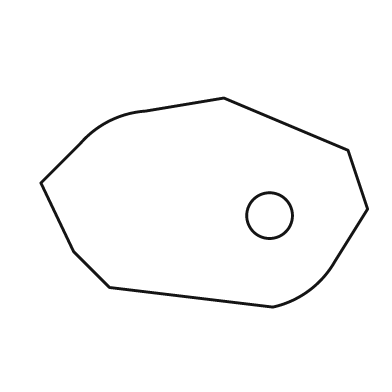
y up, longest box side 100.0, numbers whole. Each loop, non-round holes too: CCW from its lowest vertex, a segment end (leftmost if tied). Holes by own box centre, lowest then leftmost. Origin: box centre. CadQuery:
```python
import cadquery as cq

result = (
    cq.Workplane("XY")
    .moveTo(21.0, -32.0)
    .threePointArc((32.0, -27.0), (40.0, -18.0))
    .lineTo(50.0, -2.0)
    .lineTo(44.0, 16.0)
    .lineTo(6.0, 32.0)
    .lineTo(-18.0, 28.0)
    .threePointArc((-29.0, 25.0), (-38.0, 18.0))
    .lineTo(-50.0, 6.0)
    .lineTo(-40.0, -15.0)
    .lineTo(-29.0, -26.0)
    .close()
    .moveTo(20.0, -4.0)
    .circle(7.0)
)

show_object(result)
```